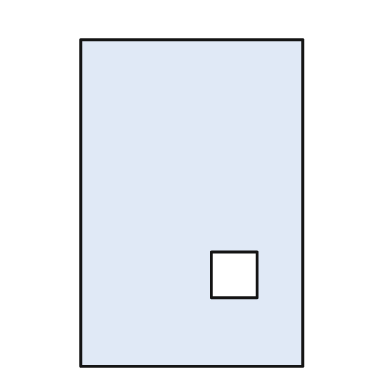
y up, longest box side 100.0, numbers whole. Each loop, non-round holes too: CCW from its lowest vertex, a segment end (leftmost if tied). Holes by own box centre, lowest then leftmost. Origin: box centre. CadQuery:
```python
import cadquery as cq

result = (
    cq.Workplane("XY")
    .moveTo(-34.0, -50.0)
    .lineTo(34.0, -50.0)
    .lineTo(34.0, 50.0)
    .lineTo(-34.0, 50.0)
    .close()
    .moveTo(6.0, -29.0)
    .lineTo(20.0, -29.0)
    .lineTo(20.0, -15.0)
    .lineTo(6.0, -15.0)
    .close()
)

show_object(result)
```